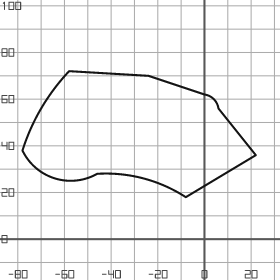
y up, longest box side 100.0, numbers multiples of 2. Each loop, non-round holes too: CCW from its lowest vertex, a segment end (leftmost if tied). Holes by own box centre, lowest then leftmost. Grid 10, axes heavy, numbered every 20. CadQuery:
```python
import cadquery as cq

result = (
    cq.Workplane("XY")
    .moveTo(-8.0, 18.0)
    .lineTo(22.0, 36.0)
    .lineTo(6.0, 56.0)
    .threePointArc((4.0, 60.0), (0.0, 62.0))
    .lineTo(-24.0, 70.0)
    .lineTo(-58.0, 72.0)
    .threePointArc((-70.0, 56.0), (-78.0, 38.0))
    .threePointArc((-64.0, 26.0), (-46.0, 28.0))
    .threePointArc((-26.0, 26.0), (-8.0, 18.0))
    .close()
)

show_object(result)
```